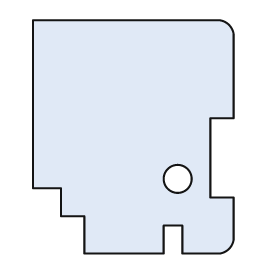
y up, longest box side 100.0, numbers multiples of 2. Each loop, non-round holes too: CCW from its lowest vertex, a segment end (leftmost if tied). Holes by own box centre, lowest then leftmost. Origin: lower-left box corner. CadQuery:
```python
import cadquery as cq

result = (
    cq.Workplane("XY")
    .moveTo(22.0, 0.0)
    .lineTo(56.0, 0.0)
    .lineTo(56.0, 12.0)
    .lineTo(64.0, 12.0)
    .lineTo(64.0, 0.0)
    .lineTo(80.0, 0.0)
    .threePointArc((84.0, 2.0), (86.0, 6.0))
    .lineTo(86.0, 24.0)
    .lineTo(76.0, 24.0)
    .lineTo(76.0, 58.0)
    .lineTo(86.0, 58.0)
    .lineTo(86.0, 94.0)
    .threePointArc((84.0, 98.0), (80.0, 100.0))
    .lineTo(0.0, 100.0)
    .lineTo(0.0, 28.0)
    .lineTo(12.0, 28.0)
    .lineTo(12.0, 16.0)
    .lineTo(22.0, 16.0)
    .close()
    .moveTo(62.0, 32.0)
    .circle(6.0)
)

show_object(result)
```